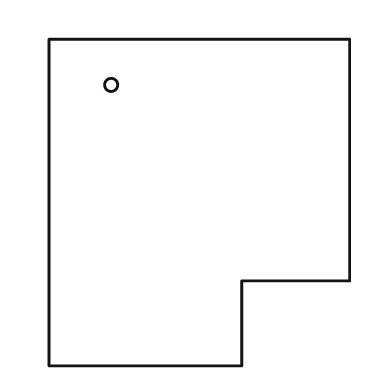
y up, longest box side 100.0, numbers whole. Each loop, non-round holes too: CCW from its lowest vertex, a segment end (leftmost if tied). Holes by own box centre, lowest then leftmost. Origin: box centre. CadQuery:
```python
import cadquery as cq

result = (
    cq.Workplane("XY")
    .moveTo(-46.0, -50.0)
    .lineTo(13.0, -50.0)
    .lineTo(13.0, -24.0)
    .lineTo(46.0, -24.0)
    .lineTo(46.0, 50.0)
    .lineTo(-46.0, 50.0)
    .close()
    .moveTo(-27.0, 36.0)
    .circle(2.0)
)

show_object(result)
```